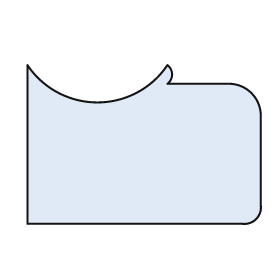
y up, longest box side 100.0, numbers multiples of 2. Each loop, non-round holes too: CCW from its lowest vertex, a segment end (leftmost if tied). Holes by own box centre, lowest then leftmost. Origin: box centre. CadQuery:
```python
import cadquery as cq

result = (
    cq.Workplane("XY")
    .moveTo(-50.0, -34.0)
    .lineTo(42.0, -34.0)
    .threePointArc((48.0, -32.0), (50.0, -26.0))
    .lineTo(50.0, 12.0)
    .threePointArc((46.0, 22.0), (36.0, 26.0))
    .lineTo(10.0, 26.0)
    .threePointArc((12.0, 30.0), (10.0, 34.0))
    .threePointArc((-20.0, 18.0), (-50.0, 34.0))
    .close()
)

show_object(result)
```